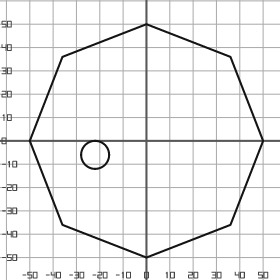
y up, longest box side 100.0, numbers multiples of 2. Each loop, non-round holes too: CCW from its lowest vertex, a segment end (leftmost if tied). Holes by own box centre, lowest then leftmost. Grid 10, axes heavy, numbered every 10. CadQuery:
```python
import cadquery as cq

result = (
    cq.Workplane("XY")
    .moveTo(0.0, -50.0)
    .lineTo(36.0, -36.0)
    .lineTo(50.0, 0.0)
    .lineTo(36.0, 36.0)
    .lineTo(0.0, 50.0)
    .lineTo(-36.0, 36.0)
    .lineTo(-50.0, 0.0)
    .lineTo(-36.0, -36.0)
    .close()
    .moveTo(-22.0, -6.0)
    .circle(6.0)
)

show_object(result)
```